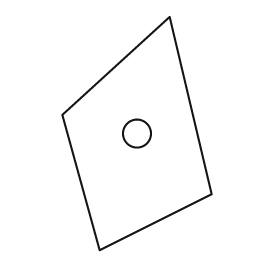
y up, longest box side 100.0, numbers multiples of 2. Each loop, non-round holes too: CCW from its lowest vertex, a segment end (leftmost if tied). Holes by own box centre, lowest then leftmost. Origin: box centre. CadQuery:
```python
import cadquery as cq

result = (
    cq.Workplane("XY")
    .moveTo(-16.0, -50.0)
    .lineTo(32.0, -26.0)
    .lineTo(14.0, 50.0)
    .lineTo(-32.0, 8.0)
    .close()
    .moveTo(0.0, 0.0)
    .circle(6.0)
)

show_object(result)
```